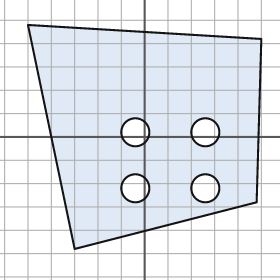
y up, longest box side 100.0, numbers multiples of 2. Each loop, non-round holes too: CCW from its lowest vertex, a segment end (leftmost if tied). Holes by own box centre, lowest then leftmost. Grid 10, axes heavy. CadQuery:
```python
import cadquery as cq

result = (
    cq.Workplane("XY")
    .moveTo(-30.0, -48.0)
    .lineTo(48.0, -28.0)
    .lineTo(50.0, 42.0)
    .lineTo(-50.0, 48.0)
    .close()
    .moveTo(-4.0, -22.0)
    .circle(6.0)
    .moveTo(26.0, -22.0)
    .circle(6.0)
    .moveTo(-4.0, 2.0)
    .circle(6.0)
    .moveTo(26.0, 2.0)
    .circle(6.0)
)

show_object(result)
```